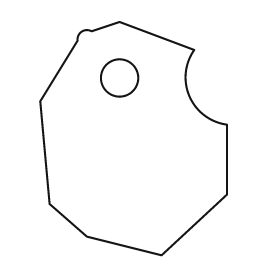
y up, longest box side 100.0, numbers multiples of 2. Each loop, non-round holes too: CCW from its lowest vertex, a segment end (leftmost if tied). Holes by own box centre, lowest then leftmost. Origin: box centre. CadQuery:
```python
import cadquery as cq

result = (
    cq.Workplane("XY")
    .moveTo(12.0, -50.0)
    .lineTo(40.0, -24.0)
    .lineTo(40.0, 6.0)
    .threePointArc((24.0, 18.0), (26.0, 38.0))
    .lineTo(-6.0, 50.0)
    .lineTo(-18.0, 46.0)
    .threePointArc((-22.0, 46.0), (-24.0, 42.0))
    .lineTo(-40.0, 16.0)
    .lineTo(-36.0, -28.0)
    .lineTo(-20.0, -42.0)
    .close()
    .moveTo(-6.0, 26.0)
    .circle(8.0)
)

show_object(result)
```